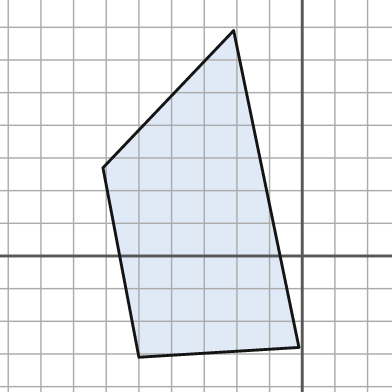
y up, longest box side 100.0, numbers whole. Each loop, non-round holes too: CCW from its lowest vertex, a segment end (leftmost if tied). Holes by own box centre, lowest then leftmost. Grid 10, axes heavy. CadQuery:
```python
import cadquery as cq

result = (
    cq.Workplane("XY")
    .moveTo(-50.0, -31.0)
    .lineTo(-1.0, -28.0)
    .lineTo(-21.0, 69.0)
    .lineTo(-61.0, 27.0)
    .close()
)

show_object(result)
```